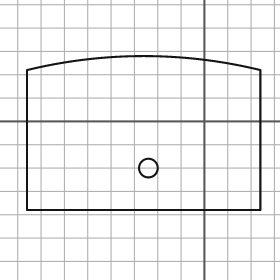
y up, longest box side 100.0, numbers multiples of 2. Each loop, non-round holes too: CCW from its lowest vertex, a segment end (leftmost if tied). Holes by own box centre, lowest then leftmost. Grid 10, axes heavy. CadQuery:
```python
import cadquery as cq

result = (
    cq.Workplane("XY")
    .moveTo(-76.0, -38.0)
    .lineTo(24.0, -38.0)
    .lineTo(24.0, 22.0)
    .threePointArc((-26.0, 28.0), (-76.0, 22.0))
    .close()
    .moveTo(-24.0, -20.0)
    .circle(4.0)
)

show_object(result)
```